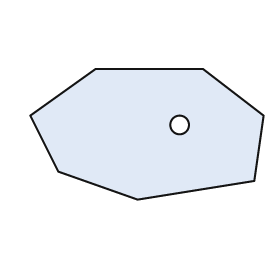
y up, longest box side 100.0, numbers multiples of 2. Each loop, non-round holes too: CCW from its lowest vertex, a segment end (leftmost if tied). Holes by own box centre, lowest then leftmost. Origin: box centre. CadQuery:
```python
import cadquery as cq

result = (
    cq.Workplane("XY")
    .moveTo(-4.0, -28.0)
    .lineTo(46.0, -20.0)
    .lineTo(50.0, 8.0)
    .lineTo(24.0, 28.0)
    .lineTo(-22.0, 28.0)
    .lineTo(-50.0, 8.0)
    .lineTo(-38.0, -16.0)
    .close()
    .moveTo(14.0, 4.0)
    .circle(4.0)
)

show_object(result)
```